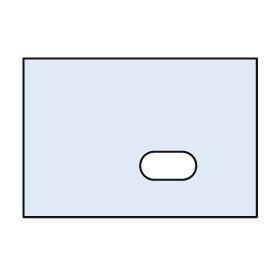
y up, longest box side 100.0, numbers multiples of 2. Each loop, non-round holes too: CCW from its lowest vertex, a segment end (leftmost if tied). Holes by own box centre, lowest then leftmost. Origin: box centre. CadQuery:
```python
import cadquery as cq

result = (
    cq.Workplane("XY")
    .moveTo(-50.0, -34.0)
    .lineTo(50.0, -34.0)
    .lineTo(50.0, 34.0)
    .lineTo(-50.0, 34.0)
    .close()
    .moveTo(6.0, -18.0)
    .lineTo(18.0, -18.0)
    .threePointArc((24.0, -12.0), (18.0, -6.0))
    .lineTo(6.0, -6.0)
    .threePointArc((0.0, -12.0), (6.0, -18.0))
    .close()
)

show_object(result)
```